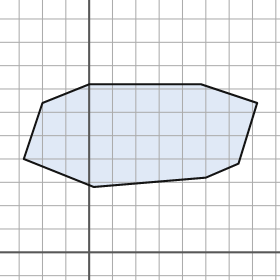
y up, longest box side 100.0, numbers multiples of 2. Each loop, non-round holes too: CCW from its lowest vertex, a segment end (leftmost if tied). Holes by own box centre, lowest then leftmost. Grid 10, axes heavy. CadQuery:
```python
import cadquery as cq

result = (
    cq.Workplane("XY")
    .moveTo(2.0, 28.0)
    .lineTo(50.0, 32.0)
    .lineTo(64.0, 38.0)
    .lineTo(72.0, 64.0)
    .lineTo(48.0, 72.0)
    .lineTo(0.0, 72.0)
    .lineTo(-20.0, 64.0)
    .lineTo(-28.0, 40.0)
    .close()
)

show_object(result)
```